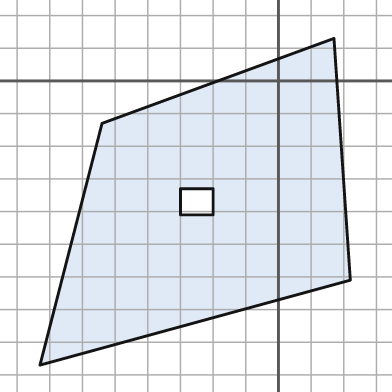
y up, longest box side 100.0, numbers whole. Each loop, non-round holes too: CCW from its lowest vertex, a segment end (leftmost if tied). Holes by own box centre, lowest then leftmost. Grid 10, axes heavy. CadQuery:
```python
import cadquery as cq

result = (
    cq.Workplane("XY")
    .moveTo(-73.0, -87.0)
    .lineTo(22.0, -61.0)
    .lineTo(17.0, 13.0)
    .lineTo(-54.0, -13.0)
    .close()
    .moveTo(-30.0, -41.0)
    .lineTo(-20.0, -41.0)
    .lineTo(-20.0, -33.0)
    .lineTo(-30.0, -33.0)
    .close()
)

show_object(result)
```